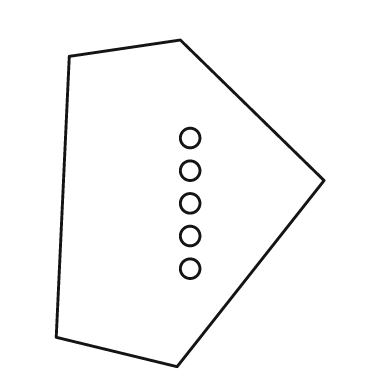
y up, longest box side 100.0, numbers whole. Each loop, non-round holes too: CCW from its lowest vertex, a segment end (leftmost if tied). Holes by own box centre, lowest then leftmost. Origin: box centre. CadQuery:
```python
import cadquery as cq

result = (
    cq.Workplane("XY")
    .moveTo(-4.0, -50.0)
    .lineTo(41.0, 7.0)
    .lineTo(-3.0, 50.0)
    .lineTo(-37.0, 45.0)
    .lineTo(-41.0, -41.0)
    .close()
    .moveTo(0.0, -20.0)
    .circle(3.0)
    .moveTo(0.0, -10.0)
    .circle(3.0)
    .moveTo(0.0, 0.0)
    .circle(3.0)
    .moveTo(0.0, 10.0)
    .circle(3.0)
    .moveTo(0.0, 20.0)
    .circle(3.0)
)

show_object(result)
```